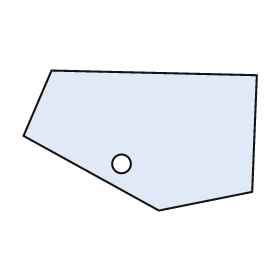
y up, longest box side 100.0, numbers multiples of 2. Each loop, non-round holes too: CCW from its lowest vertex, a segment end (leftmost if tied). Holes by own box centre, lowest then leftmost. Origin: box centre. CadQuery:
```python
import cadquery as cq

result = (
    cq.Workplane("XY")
    .moveTo(8.0, -30.0)
    .lineTo(48.0, -22.0)
    .lineTo(50.0, 28.0)
    .lineTo(-38.0, 30.0)
    .lineTo(-50.0, 2.0)
    .close()
    .moveTo(-8.0, -10.0)
    .circle(4.0)
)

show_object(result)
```